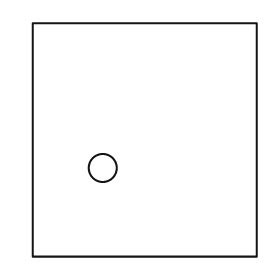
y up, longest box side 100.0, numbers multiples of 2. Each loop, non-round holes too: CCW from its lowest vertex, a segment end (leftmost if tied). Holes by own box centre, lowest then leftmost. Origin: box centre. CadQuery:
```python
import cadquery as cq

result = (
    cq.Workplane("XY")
    .moveTo(-48.0, -50.0)
    .lineTo(48.0, -50.0)
    .lineTo(48.0, 50.0)
    .lineTo(-48.0, 50.0)
    .close()
    .moveTo(-18.0, -12.0)
    .circle(6.0)
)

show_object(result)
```